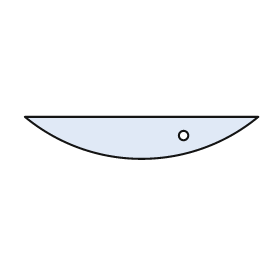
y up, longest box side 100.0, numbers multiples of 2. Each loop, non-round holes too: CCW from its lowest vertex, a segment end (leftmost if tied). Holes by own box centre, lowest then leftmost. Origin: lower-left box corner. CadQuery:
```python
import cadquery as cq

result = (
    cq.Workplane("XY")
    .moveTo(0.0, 18.0)
    .threePointArc((50.0, 0.0), (100.0, 18.0))
    .close()
    .moveTo(68.0, 10.0)
    .circle(2.0)
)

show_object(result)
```